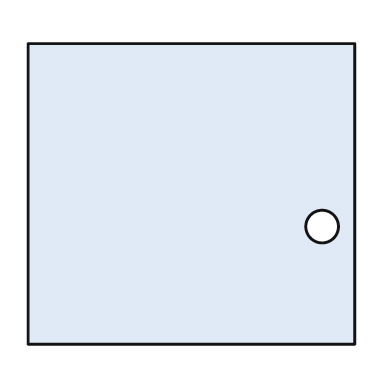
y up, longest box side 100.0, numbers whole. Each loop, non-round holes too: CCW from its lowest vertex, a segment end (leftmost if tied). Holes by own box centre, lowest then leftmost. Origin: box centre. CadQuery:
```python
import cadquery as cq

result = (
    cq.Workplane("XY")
    .moveTo(-50.0, -46.0)
    .lineTo(50.0, -46.0)
    .lineTo(50.0, 46.0)
    .lineTo(-50.0, 46.0)
    .close()
    .moveTo(40.0, -10.0)
    .circle(5.0)
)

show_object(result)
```